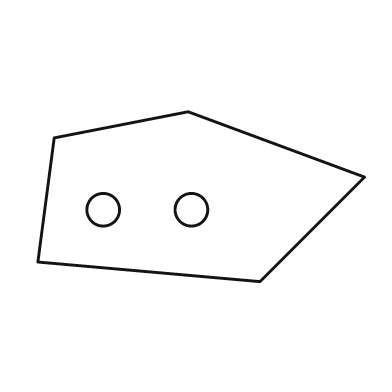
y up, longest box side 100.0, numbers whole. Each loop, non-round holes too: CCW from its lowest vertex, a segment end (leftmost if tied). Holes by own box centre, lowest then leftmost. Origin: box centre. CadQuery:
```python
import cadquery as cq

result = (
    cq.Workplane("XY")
    .moveTo(18.0, -26.0)
    .lineTo(50.0, 6.0)
    .lineTo(-4.0, 26.0)
    .lineTo(-45.0, 18.0)
    .lineTo(-50.0, -20.0)
    .close()
    .moveTo(-30.0, -4.0)
    .circle(5.0)
    .moveTo(-3.0, -4.0)
    .circle(5.0)
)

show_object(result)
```